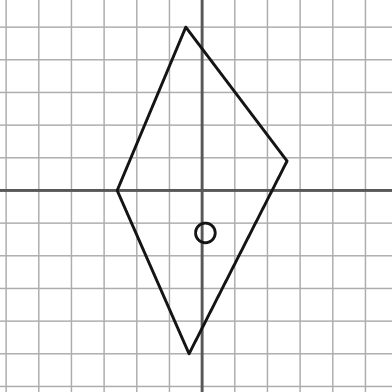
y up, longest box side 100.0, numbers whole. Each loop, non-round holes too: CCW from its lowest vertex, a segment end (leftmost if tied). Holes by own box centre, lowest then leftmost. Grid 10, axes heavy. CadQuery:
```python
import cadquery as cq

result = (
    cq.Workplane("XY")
    .moveTo(-4.0, -50.0)
    .lineTo(26.0, 9.0)
    .lineTo(-5.0, 50.0)
    .lineTo(-26.0, 0.0)
    .close()
    .moveTo(1.0, -13.0)
    .circle(3.0)
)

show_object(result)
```